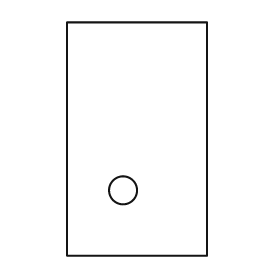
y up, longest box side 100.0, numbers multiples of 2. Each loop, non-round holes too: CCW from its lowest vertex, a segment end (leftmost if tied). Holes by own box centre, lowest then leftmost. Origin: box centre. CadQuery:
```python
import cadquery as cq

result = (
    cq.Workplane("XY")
    .moveTo(-30.0, -50.0)
    .lineTo(30.0, -50.0)
    .lineTo(30.0, 50.0)
    .lineTo(-30.0, 50.0)
    .close()
    .moveTo(-6.0, -22.0)
    .circle(6.0)
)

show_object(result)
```